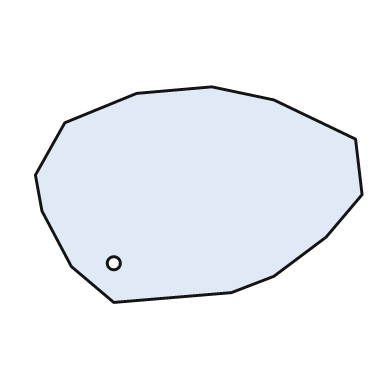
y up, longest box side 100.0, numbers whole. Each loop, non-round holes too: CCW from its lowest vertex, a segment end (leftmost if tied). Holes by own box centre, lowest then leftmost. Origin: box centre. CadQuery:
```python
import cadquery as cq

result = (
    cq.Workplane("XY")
    .moveTo(-26.0, -33.0)
    .lineTo(10.0, -30.0)
    .lineTo(23.0, -25.0)
    .lineTo(39.0, -13.0)
    .lineTo(50.0, 0.0)
    .lineTo(48.0, 17.0)
    .lineTo(23.0, 29.0)
    .lineTo(4.0, 33.0)
    .lineTo(-19.0, 31.0)
    .lineTo(-41.0, 22.0)
    .lineTo(-50.0, 6.0)
    .lineTo(-48.0, -5.0)
    .lineTo(-39.0, -22.0)
    .close()
    .moveTo(-26.0, -21.0)
    .circle(2.0)
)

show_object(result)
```